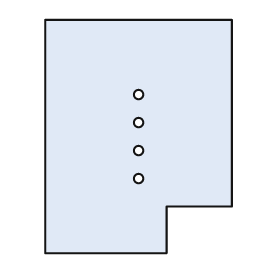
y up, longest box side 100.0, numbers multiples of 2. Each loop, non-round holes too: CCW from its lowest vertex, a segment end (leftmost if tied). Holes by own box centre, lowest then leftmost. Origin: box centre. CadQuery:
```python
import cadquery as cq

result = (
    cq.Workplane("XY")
    .moveTo(-40.0, -50.0)
    .lineTo(12.0, -50.0)
    .lineTo(12.0, -30.0)
    .lineTo(40.0, -30.0)
    .lineTo(40.0, 50.0)
    .lineTo(-40.0, 50.0)
    .close()
    .moveTo(0.0, -18.0)
    .circle(2.0)
    .moveTo(0.0, -6.0)
    .circle(2.0)
    .moveTo(0.0, 6.0)
    .circle(2.0)
    .moveTo(0.0, 18.0)
    .circle(2.0)
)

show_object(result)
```